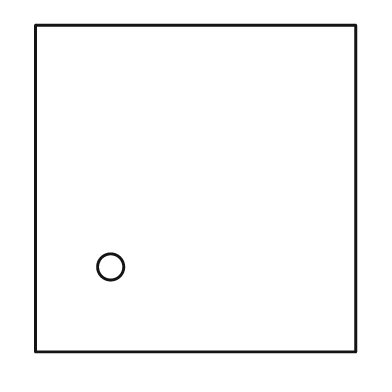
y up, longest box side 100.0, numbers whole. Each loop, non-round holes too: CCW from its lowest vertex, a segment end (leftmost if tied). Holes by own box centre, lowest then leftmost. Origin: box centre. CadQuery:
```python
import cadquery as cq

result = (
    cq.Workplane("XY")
    .moveTo(-49.0, -50.0)
    .lineTo(49.0, -50.0)
    .lineTo(49.0, 50.0)
    .lineTo(-49.0, 50.0)
    .close()
    .moveTo(-26.0, -24.0)
    .circle(4.0)
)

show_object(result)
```